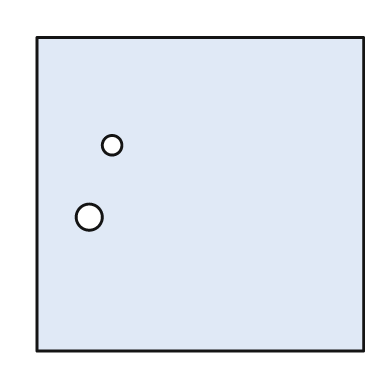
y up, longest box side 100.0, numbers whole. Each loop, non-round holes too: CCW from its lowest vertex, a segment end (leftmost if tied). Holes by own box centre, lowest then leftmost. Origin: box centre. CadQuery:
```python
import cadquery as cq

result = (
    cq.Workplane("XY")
    .moveTo(-50.0, -48.0)
    .lineTo(50.0, -48.0)
    .lineTo(50.0, 48.0)
    .lineTo(-50.0, 48.0)
    .close()
    .moveTo(-34.0, -7.0)
    .circle(4.0)
    .moveTo(-27.0, 15.0)
    .circle(3.0)
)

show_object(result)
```